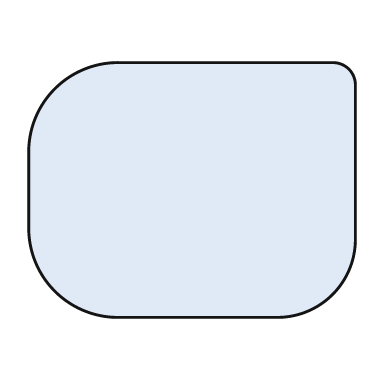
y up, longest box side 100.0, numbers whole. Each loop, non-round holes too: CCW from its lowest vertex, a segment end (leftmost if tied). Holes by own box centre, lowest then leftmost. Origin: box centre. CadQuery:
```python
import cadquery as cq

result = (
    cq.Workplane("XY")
    .moveTo(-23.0, -39.0)
    .lineTo(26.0, -39.0)
    .threePointArc((43.0, -32.0), (50.0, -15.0))
    .lineTo(50.0, 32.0)
    .threePointArc((48.0, 37.0), (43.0, 39.0))
    .lineTo(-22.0, 39.0)
    .threePointArc((-42.0, 31.0), (-50.0, 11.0))
    .lineTo(-50.0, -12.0)
    .threePointArc((-42.0, -31.0), (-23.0, -39.0))
    .close()
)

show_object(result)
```